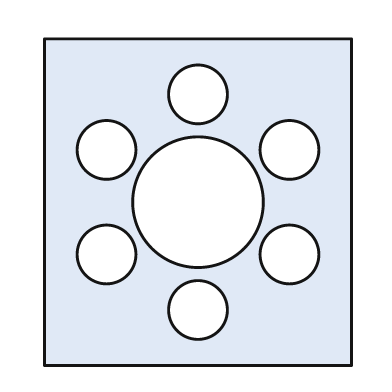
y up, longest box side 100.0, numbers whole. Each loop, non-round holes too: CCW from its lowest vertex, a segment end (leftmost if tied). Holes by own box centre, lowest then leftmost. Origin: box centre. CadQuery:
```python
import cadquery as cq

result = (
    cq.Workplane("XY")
    .moveTo(-47.0, -50.0)
    .lineTo(47.0, -50.0)
    .lineTo(47.0, 50.0)
    .lineTo(-47.0, 50.0)
    .close()
    .moveTo(0.0, -33.0)
    .circle(9.0)
    .moveTo(-28.0, -16.0)
    .circle(9.0)
    .moveTo(28.0, -16.0)
    .circle(9.0)
    .moveTo(0.0, 0.0)
    .circle(20.0)
    .moveTo(-28.0, 16.0)
    .circle(9.0)
    .moveTo(28.0, 16.0)
    .circle(9.0)
    .moveTo(0.0, 33.0)
    .circle(9.0)
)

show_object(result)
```